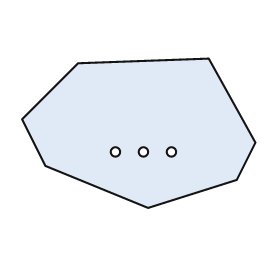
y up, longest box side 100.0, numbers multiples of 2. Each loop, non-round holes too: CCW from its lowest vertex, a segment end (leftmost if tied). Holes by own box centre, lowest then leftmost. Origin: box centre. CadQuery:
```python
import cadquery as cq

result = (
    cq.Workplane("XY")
    .moveTo(4.0, -32.0)
    .lineTo(42.0, -20.0)
    .lineTo(50.0, -4.0)
    .lineTo(30.0, 32.0)
    .lineTo(-26.0, 30.0)
    .lineTo(-50.0, 6.0)
    .lineTo(-40.0, -14.0)
    .close()
    .moveTo(-10.0, -8.0)
    .circle(2.0)
    .moveTo(2.0, -8.0)
    .circle(2.0)
    .moveTo(14.0, -8.0)
    .circle(2.0)
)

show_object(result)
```